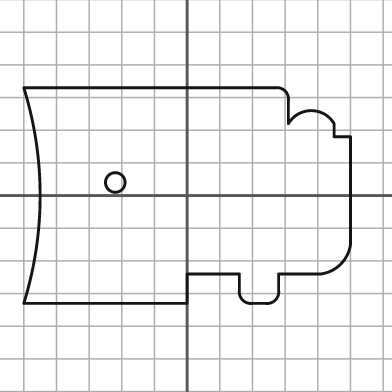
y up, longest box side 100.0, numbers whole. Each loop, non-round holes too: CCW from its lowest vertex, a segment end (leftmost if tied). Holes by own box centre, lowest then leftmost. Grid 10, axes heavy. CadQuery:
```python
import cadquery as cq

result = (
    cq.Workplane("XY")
    .moveTo(-50.0, -33.0)
    .lineTo(0.0, -33.0)
    .lineTo(0.0, -24.0)
    .lineTo(16.0, -24.0)
    .lineTo(16.0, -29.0)
    .threePointArc((17.0, -32.0), (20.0, -33.0))
    .lineTo(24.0, -33.0)
    .threePointArc((27.0, -32.0), (28.0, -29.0))
    .lineTo(28.0, -24.0)
    .lineTo(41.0, -24.0)
    .threePointArc((47.0, -21.0), (50.0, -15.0))
    .lineTo(50.0, 18.0)
    .lineTo(45.0, 18.0)
    .lineTo(45.0, 22.0)
    .threePointArc((38.0, 26.0), (31.0, 22.0))
    .lineTo(31.0, 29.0)
    .threePointArc((30.0, 32.0), (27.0, 33.0))
    .lineTo(-50.0, 33.0)
    .threePointArc((-45.0, 0.0), (-50.0, -33.0))
    .close()
    .moveTo(-22.0, 4.0)
    .circle(3.0)
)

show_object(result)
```